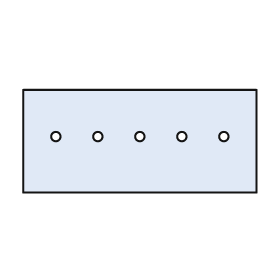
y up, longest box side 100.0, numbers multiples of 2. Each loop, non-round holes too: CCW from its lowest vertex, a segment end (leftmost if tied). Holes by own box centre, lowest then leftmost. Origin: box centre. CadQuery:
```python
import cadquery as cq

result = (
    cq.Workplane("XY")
    .moveTo(-50.0, -22.0)
    .lineTo(50.0, -22.0)
    .lineTo(50.0, 22.0)
    .lineTo(-50.0, 22.0)
    .close()
    .moveTo(-36.0, 2.0)
    .circle(2.0)
    .moveTo(-18.0, 2.0)
    .circle(2.0)
    .moveTo(0.0, 2.0)
    .circle(2.0)
    .moveTo(18.0, 2.0)
    .circle(2.0)
    .moveTo(36.0, 2.0)
    .circle(2.0)
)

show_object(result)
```